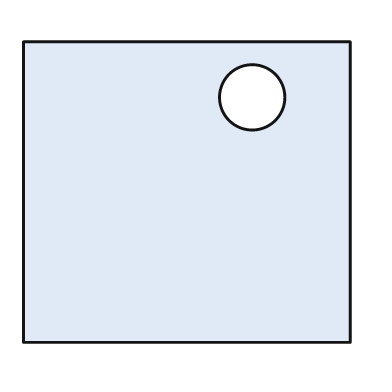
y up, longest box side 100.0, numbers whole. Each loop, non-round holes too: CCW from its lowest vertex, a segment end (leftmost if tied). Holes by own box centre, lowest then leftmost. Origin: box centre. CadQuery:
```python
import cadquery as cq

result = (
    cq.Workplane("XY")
    .moveTo(-50.0, -46.0)
    .lineTo(50.0, -46.0)
    .lineTo(50.0, 46.0)
    .lineTo(-50.0, 46.0)
    .close()
    .moveTo(20.0, 29.0)
    .circle(10.0)
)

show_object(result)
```